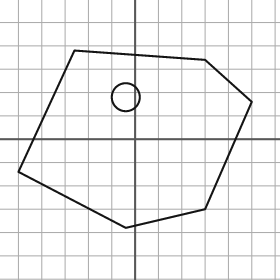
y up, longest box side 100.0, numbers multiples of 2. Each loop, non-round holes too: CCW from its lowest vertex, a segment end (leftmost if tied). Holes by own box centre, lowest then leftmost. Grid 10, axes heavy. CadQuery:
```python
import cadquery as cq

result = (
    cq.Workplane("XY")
    .moveTo(-4.0, -38.0)
    .lineTo(30.0, -30.0)
    .lineTo(50.0, 16.0)
    .lineTo(30.0, 34.0)
    .lineTo(-26.0, 38.0)
    .lineTo(-50.0, -14.0)
    .close()
    .moveTo(-4.0, 18.0)
    .circle(6.0)
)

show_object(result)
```